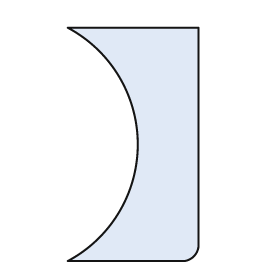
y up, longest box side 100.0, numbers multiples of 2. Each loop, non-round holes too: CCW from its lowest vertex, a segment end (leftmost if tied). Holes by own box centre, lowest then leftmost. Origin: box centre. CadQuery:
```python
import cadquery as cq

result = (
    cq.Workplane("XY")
    .moveTo(-28.0, -50.0)
    .lineTo(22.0, -50.0)
    .threePointArc((26.0, -48.0), (28.0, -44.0))
    .lineTo(28.0, 50.0)
    .lineTo(-28.0, 50.0)
    .threePointArc((2.0, 0.0), (-28.0, -50.0))
    .close()
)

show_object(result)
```